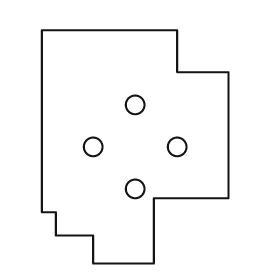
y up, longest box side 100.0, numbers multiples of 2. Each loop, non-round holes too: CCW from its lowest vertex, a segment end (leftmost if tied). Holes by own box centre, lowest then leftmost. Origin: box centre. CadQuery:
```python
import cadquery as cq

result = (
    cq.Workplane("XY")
    .moveTo(-18.0, -50.0)
    .lineTo(8.0, -50.0)
    .lineTo(8.0, -22.0)
    .lineTo(40.0, -22.0)
    .lineTo(40.0, 32.0)
    .lineTo(18.0, 32.0)
    .lineTo(18.0, 50.0)
    .lineTo(-40.0, 50.0)
    .lineTo(-40.0, -28.0)
    .lineTo(-34.0, -28.0)
    .lineTo(-34.0, -38.0)
    .lineTo(-18.0, -38.0)
    .close()
    .moveTo(0.0, -18.0)
    .circle(4.0)
    .moveTo(-18.0, 0.0)
    .circle(4.0)
    .moveTo(18.0, 0.0)
    .circle(4.0)
    .moveTo(0.0, 18.0)
    .circle(4.0)
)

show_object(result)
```